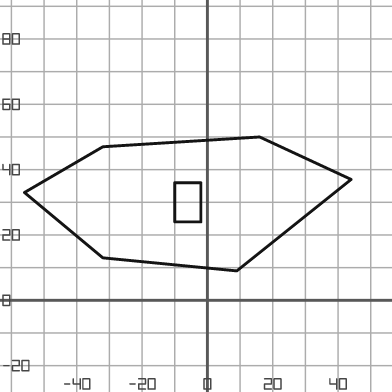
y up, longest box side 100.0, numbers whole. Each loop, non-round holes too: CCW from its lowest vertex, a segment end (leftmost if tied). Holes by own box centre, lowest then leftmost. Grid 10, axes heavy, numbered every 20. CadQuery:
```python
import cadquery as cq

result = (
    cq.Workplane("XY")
    .moveTo(9.0, 9.0)
    .lineTo(44.0, 37.0)
    .lineTo(16.0, 50.0)
    .lineTo(-32.0, 47.0)
    .lineTo(-56.0, 33.0)
    .lineTo(-32.0, 13.0)
    .close()
    .moveTo(-10.0, 24.0)
    .lineTo(-2.0, 24.0)
    .lineTo(-2.0, 36.0)
    .lineTo(-10.0, 36.0)
    .close()
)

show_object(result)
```